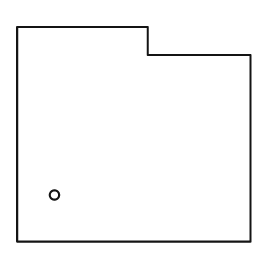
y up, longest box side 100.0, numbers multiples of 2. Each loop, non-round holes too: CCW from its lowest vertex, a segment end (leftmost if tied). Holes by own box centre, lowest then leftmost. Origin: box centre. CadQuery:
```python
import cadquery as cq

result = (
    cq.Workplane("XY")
    .moveTo(-50.0, -46.0)
    .lineTo(50.0, -46.0)
    .lineTo(50.0, 34.0)
    .lineTo(6.0, 34.0)
    .lineTo(6.0, 46.0)
    .lineTo(-50.0, 46.0)
    .close()
    .moveTo(-34.0, -26.0)
    .circle(2.0)
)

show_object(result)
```